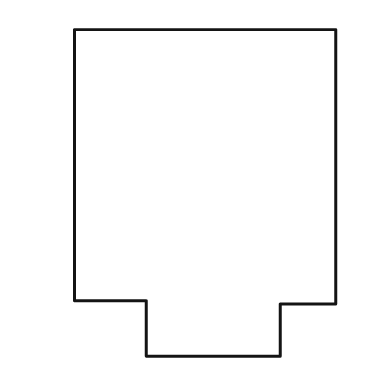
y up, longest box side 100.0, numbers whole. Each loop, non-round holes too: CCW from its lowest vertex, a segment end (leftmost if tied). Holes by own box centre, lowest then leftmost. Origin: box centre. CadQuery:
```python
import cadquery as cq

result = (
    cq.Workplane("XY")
    .moveTo(-18.0, -50.0)
    .lineTo(23.0, -50.0)
    .lineTo(23.0, -34.0)
    .lineTo(40.0, -34.0)
    .lineTo(40.0, 50.0)
    .lineTo(-40.0, 50.0)
    .lineTo(-40.0, -33.0)
    .lineTo(-18.0, -33.0)
    .close()
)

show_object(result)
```